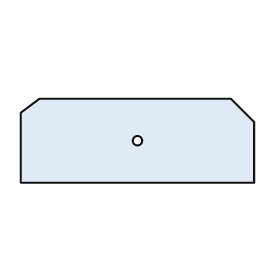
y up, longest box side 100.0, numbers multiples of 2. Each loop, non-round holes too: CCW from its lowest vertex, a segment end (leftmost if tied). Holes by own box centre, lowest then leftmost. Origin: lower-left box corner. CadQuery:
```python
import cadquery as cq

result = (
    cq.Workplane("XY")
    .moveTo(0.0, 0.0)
    .lineTo(100.0, 0.0)
    .lineTo(100.0, 26.0)
    .lineTo(90.0, 36.0)
    .lineTo(8.0, 36.0)
    .lineTo(0.0, 30.0)
    .close()
    .moveTo(50.0, 18.0)
    .circle(2.0)
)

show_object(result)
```